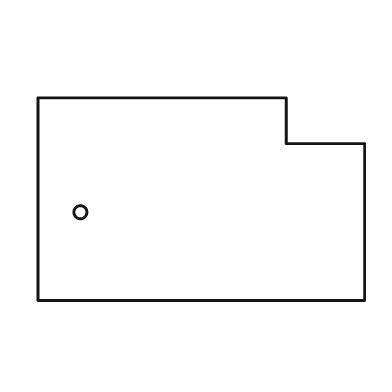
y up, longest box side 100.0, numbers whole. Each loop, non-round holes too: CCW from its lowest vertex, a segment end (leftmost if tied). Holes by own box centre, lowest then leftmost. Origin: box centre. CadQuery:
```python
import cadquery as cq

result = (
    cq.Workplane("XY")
    .moveTo(-50.0, -31.0)
    .lineTo(50.0, -31.0)
    .lineTo(50.0, 17.0)
    .lineTo(26.0, 17.0)
    .lineTo(26.0, 31.0)
    .lineTo(-50.0, 31.0)
    .close()
    .moveTo(-37.0, -4.0)
    .circle(2.0)
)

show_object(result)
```